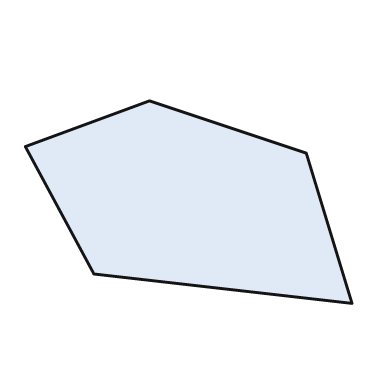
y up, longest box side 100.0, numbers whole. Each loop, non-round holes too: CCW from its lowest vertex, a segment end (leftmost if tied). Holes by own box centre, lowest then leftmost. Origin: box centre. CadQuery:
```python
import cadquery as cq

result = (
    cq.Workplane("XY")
    .moveTo(50.0, -31.0)
    .lineTo(36.0, 15.0)
    .lineTo(-12.0, 31.0)
    .lineTo(-50.0, 17.0)
    .lineTo(-29.0, -22.0)
    .close()
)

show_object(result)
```